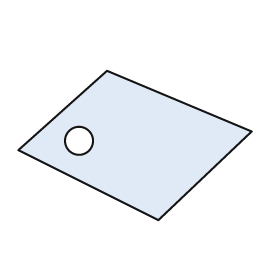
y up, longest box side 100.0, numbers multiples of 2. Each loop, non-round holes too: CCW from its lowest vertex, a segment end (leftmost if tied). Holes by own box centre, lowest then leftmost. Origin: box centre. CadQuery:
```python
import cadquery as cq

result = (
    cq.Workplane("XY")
    .moveTo(10.0, -32.0)
    .lineTo(50.0, 6.0)
    .lineTo(-12.0, 32.0)
    .lineTo(-50.0, -2.0)
    .close()
    .moveTo(-24.0, 2.0)
    .circle(6.0)
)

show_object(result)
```